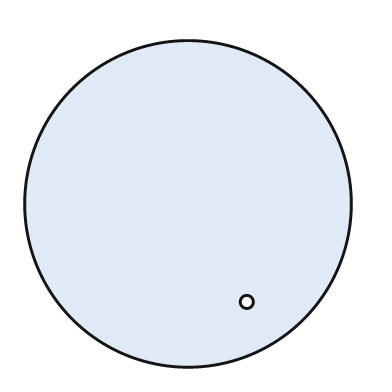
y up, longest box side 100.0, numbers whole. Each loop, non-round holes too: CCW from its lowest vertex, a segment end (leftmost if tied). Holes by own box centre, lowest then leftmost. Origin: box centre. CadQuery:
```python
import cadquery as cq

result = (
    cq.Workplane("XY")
    .moveTo(0.0, 0.0)
    .circle(50.0)
    .moveTo(18.0, -30.0)
    .circle(2.0)
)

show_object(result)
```